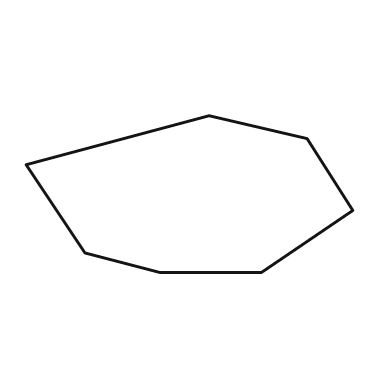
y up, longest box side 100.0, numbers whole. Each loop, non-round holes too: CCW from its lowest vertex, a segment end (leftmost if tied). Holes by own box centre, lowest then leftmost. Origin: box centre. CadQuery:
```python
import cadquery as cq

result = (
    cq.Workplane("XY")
    .moveTo(-9.0, -24.0)
    .lineTo(22.0, -24.0)
    .lineTo(50.0, -5.0)
    .lineTo(36.0, 17.0)
    .lineTo(6.0, 24.0)
    .lineTo(-50.0, 9.0)
    .lineTo(-32.0, -18.0)
    .close()
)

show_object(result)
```